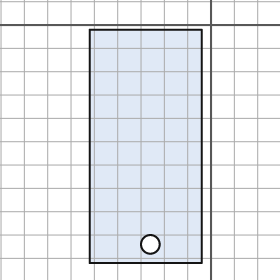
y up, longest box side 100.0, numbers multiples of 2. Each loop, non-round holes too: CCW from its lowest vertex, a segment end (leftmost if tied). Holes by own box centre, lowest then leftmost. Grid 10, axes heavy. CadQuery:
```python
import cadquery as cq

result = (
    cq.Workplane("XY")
    .moveTo(-52.0, -102.0)
    .lineTo(-4.0, -102.0)
    .lineTo(-4.0, -2.0)
    .lineTo(-52.0, -2.0)
    .close()
    .moveTo(-26.0, -94.0)
    .circle(4.0)
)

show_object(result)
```